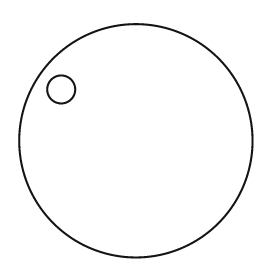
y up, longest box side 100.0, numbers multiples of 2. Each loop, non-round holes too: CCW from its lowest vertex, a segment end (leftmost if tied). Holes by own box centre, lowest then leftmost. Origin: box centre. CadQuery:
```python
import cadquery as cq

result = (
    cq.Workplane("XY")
    .moveTo(0.0, 0.0)
    .circle(50.0)
    .moveTo(-32.0, 22.0)
    .circle(6.0)
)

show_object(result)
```